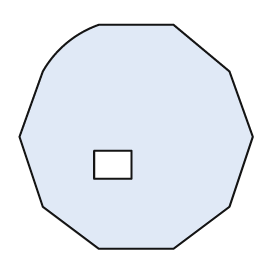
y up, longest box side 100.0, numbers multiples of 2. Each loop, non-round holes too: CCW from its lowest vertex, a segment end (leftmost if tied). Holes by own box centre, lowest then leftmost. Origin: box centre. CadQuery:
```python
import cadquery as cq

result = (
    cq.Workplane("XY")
    .moveTo(-16.0, -48.0)
    .lineTo(16.0, -48.0)
    .lineTo(40.0, -30.0)
    .lineTo(50.0, 0.0)
    .lineTo(40.0, 28.0)
    .lineTo(16.0, 48.0)
    .lineTo(-16.0, 48.0)
    .threePointArc((-30.0, 40.0), (-40.0, 28.0))
    .lineTo(-50.0, 0.0)
    .lineTo(-40.0, -30.0)
    .close()
    .moveTo(-18.0, -18.0)
    .lineTo(-2.0, -18.0)
    .lineTo(-2.0, -6.0)
    .lineTo(-18.0, -6.0)
    .close()
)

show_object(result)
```